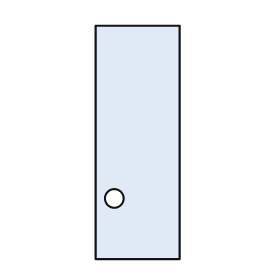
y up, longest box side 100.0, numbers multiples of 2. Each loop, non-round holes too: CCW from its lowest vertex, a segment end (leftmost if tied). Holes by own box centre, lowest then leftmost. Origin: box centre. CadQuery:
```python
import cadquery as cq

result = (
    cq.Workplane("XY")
    .moveTo(-18.0, -50.0)
    .lineTo(18.0, -50.0)
    .lineTo(18.0, 50.0)
    .lineTo(-18.0, 50.0)
    .close()
    .moveTo(-10.0, -24.0)
    .circle(4.0)
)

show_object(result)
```